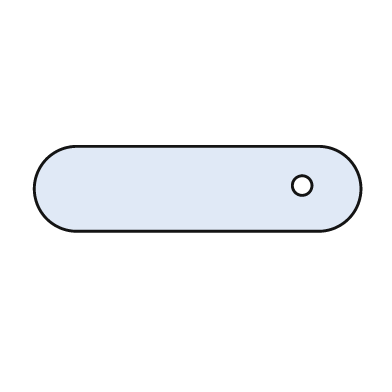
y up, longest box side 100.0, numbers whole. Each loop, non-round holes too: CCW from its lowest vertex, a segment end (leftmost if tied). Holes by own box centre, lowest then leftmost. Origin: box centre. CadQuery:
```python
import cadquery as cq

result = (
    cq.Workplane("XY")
    .moveTo(-37.0, -13.0)
    .lineTo(37.0, -13.0)
    .threePointArc((50.0, 0.0), (37.0, 13.0))
    .lineTo(-37.0, 13.0)
    .threePointArc((-50.0, 0.0), (-37.0, -13.0))
    .close()
    .moveTo(32.0, 1.0)
    .circle(3.0)
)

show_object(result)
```